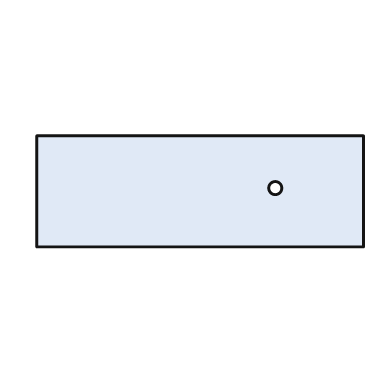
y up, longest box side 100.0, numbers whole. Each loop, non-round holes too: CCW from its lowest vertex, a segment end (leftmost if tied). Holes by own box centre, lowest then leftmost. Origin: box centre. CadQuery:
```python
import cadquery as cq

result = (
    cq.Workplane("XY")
    .moveTo(-50.0, -17.0)
    .lineTo(50.0, -17.0)
    .lineTo(50.0, 17.0)
    .lineTo(-50.0, 17.0)
    .close()
    .moveTo(23.0, 1.0)
    .circle(2.0)
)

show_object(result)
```